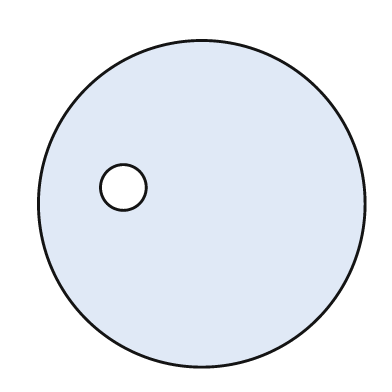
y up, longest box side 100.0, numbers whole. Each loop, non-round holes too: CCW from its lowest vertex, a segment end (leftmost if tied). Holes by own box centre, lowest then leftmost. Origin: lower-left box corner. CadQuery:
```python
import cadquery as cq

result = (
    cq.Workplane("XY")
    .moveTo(50.0, 50.0)
    .circle(50.0)
    .moveTo(26.0, 55.0)
    .circle(7.0)
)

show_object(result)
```